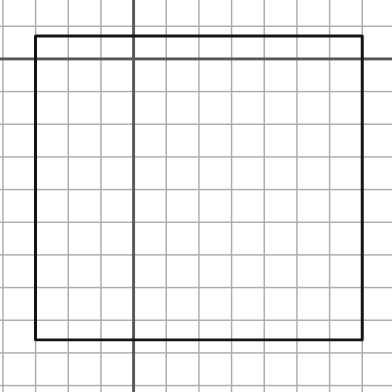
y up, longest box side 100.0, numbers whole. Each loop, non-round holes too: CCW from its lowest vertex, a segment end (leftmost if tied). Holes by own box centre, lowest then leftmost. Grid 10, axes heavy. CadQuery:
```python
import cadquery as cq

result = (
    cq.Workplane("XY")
    .moveTo(-30.0, -86.0)
    .lineTo(70.0, -86.0)
    .lineTo(70.0, 7.0)
    .lineTo(-30.0, 7.0)
    .close()
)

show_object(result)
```